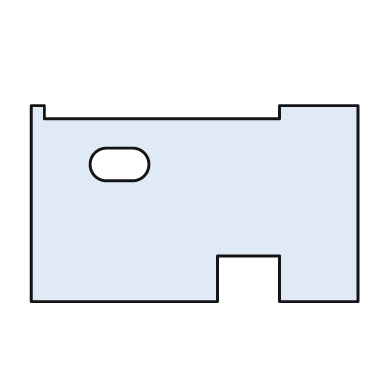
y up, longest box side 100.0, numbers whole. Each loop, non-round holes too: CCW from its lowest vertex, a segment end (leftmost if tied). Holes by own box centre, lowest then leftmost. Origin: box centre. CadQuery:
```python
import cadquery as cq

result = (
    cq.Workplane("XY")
    .moveTo(-50.0, -30.0)
    .lineTo(7.0, -30.0)
    .lineTo(7.0, -16.0)
    .lineTo(26.0, -16.0)
    .lineTo(26.0, -30.0)
    .lineTo(50.0, -30.0)
    .lineTo(50.0, 30.0)
    .lineTo(26.0, 30.0)
    .lineTo(26.0, 26.0)
    .lineTo(-46.0, 26.0)
    .lineTo(-46.0, 30.0)
    .lineTo(-50.0, 30.0)
    .close()
    .moveTo(-27.0, 7.0)
    .lineTo(-19.0, 7.0)
    .threePointArc((-14.0, 12.0), (-19.0, 17.0))
    .lineTo(-27.0, 17.0)
    .threePointArc((-32.0, 12.0), (-27.0, 7.0))
    .close()
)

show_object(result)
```